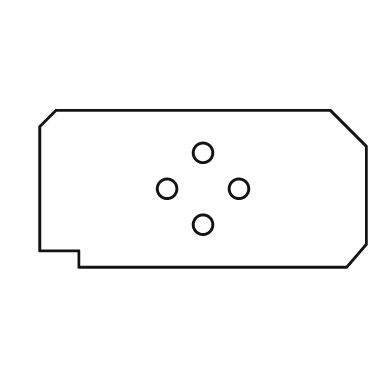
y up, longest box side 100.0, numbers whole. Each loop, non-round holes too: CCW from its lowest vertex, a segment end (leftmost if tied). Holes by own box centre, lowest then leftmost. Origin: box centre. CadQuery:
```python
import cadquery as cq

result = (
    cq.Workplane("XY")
    .moveTo(-38.0, -24.0)
    .lineTo(44.0, -24.0)
    .lineTo(50.0, -17.0)
    .lineTo(50.0, 13.0)
    .lineTo(39.0, 24.0)
    .lineTo(-45.0, 24.0)
    .lineTo(-50.0, 19.0)
    .lineTo(-50.0, -19.0)
    .lineTo(-38.0, -19.0)
    .close()
    .moveTo(0.0, -11.0)
    .circle(3.0)
    .moveTo(-11.0, 0.0)
    .circle(3.0)
    .moveTo(11.0, 0.0)
    .circle(3.0)
    .moveTo(0.0, 11.0)
    .circle(3.0)
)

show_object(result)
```